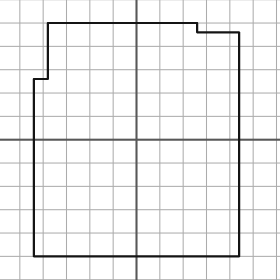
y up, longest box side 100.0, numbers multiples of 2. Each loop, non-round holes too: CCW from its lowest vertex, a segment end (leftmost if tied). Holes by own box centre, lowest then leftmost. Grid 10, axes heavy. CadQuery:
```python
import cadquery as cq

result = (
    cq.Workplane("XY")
    .moveTo(-44.0, -50.0)
    .lineTo(44.0, -50.0)
    .lineTo(44.0, 46.0)
    .lineTo(26.0, 46.0)
    .lineTo(26.0, 50.0)
    .lineTo(-38.0, 50.0)
    .lineTo(-38.0, 26.0)
    .lineTo(-44.0, 26.0)
    .close()
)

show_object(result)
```